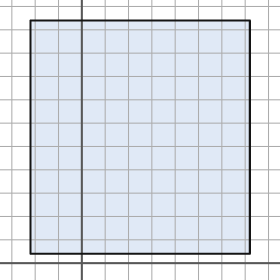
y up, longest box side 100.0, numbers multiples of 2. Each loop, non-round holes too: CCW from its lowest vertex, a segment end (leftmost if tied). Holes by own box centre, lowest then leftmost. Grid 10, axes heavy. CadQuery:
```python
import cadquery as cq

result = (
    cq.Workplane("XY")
    .moveTo(-22.0, 4.0)
    .lineTo(72.0, 4.0)
    .lineTo(72.0, 104.0)
    .lineTo(-22.0, 104.0)
    .close()
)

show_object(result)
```